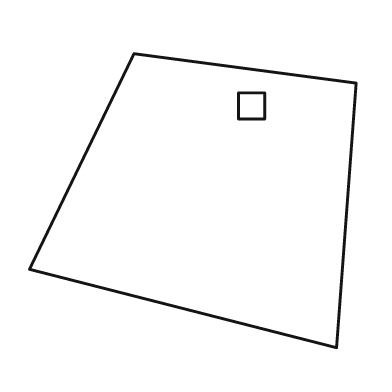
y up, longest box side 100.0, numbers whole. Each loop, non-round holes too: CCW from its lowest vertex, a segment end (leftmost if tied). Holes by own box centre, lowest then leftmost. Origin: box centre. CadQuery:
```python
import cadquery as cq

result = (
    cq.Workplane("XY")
    .moveTo(44.0, -45.0)
    .lineTo(50.0, 36.0)
    .lineTo(-18.0, 45.0)
    .lineTo(-50.0, -21.0)
    .close()
    .moveTo(14.0, 25.0)
    .lineTo(22.0, 25.0)
    .lineTo(22.0, 33.0)
    .lineTo(14.0, 33.0)
    .close()
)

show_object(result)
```